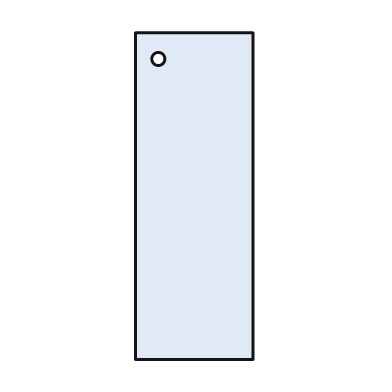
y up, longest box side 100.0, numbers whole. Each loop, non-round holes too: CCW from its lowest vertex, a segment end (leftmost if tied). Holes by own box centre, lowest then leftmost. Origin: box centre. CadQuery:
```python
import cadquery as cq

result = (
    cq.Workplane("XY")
    .moveTo(-18.0, -50.0)
    .lineTo(18.0, -50.0)
    .lineTo(18.0, 50.0)
    .lineTo(-18.0, 50.0)
    .close()
    .moveTo(-11.0, 42.0)
    .circle(2.0)
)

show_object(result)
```